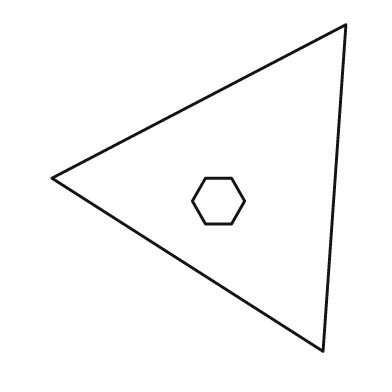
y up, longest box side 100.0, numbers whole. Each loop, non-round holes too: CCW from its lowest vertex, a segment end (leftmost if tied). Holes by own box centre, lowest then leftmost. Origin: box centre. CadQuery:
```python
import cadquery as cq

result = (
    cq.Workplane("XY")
    .moveTo(38.0, -50.0)
    .lineTo(45.0, 50.0)
    .lineTo(-45.0, 3.0)
    .close()
    .moveTo(2.0, -11.0)
    .lineTo(10.0, -11.0)
    .lineTo(14.0, -4.0)
    .lineTo(10.0, 3.0)
    .lineTo(2.0, 3.0)
    .lineTo(-2.0, -4.0)
    .close()
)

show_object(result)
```